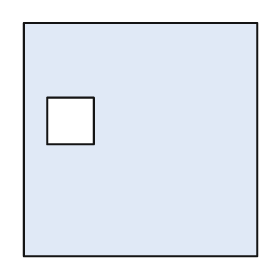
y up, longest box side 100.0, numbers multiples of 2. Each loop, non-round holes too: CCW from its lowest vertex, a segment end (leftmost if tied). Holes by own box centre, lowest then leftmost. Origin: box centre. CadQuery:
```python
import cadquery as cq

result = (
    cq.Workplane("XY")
    .moveTo(-50.0, -50.0)
    .lineTo(50.0, -50.0)
    .lineTo(50.0, 50.0)
    .lineTo(-50.0, 50.0)
    .close()
    .moveTo(-40.0, -2.0)
    .lineTo(-20.0, -2.0)
    .lineTo(-20.0, 18.0)
    .lineTo(-40.0, 18.0)
    .close()
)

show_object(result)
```